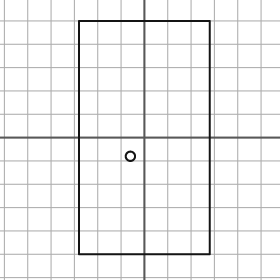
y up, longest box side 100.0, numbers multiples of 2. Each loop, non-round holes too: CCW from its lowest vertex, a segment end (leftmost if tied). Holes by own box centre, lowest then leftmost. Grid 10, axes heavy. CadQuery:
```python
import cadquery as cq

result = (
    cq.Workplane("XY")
    .moveTo(-28.0, -50.0)
    .lineTo(28.0, -50.0)
    .lineTo(28.0, 50.0)
    .lineTo(-28.0, 50.0)
    .close()
    .moveTo(-6.0, -8.0)
    .circle(2.0)
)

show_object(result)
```